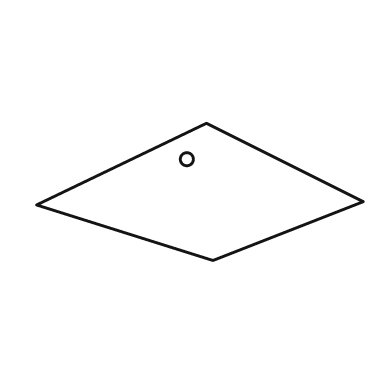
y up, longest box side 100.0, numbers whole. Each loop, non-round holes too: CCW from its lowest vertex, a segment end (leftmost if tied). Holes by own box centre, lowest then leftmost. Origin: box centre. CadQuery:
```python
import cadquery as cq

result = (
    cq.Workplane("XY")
    .moveTo(4.0, -21.0)
    .lineTo(50.0, -3.0)
    .lineTo(2.0, 21.0)
    .lineTo(-50.0, -4.0)
    .close()
    .moveTo(-4.0, 10.0)
    .circle(2.0)
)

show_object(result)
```